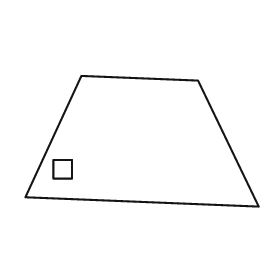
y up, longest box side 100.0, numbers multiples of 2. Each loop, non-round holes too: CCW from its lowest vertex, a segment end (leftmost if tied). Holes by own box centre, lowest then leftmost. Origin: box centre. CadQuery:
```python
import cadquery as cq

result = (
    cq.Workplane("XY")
    .moveTo(50.0, -28.0)
    .lineTo(24.0, 26.0)
    .lineTo(-26.0, 28.0)
    .lineTo(-50.0, -24.0)
    .close()
    .moveTo(-38.0, -16.0)
    .lineTo(-30.0, -16.0)
    .lineTo(-30.0, -8.0)
    .lineTo(-38.0, -8.0)
    .close()
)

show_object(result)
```